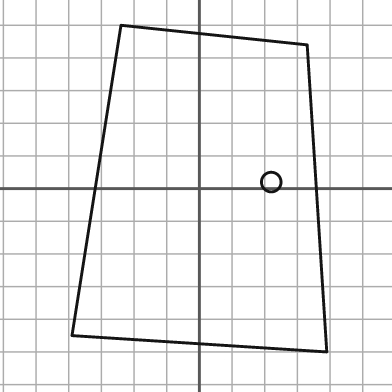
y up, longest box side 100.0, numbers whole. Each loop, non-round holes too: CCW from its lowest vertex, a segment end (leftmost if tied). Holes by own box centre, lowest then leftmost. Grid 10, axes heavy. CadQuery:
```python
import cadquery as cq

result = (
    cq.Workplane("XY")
    .moveTo(39.0, -50.0)
    .lineTo(33.0, 44.0)
    .lineTo(-24.0, 50.0)
    .lineTo(-39.0, -45.0)
    .close()
    .moveTo(22.0, 2.0)
    .circle(3.0)
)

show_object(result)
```